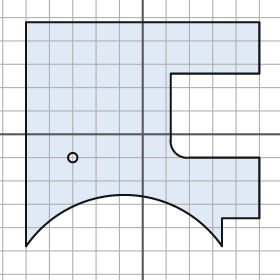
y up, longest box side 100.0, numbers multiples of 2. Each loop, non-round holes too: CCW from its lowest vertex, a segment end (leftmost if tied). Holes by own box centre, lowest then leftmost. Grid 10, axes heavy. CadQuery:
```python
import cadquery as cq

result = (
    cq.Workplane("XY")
    .moveTo(-50.0, -48.0)
    .threePointArc((-8.0, -26.0), (34.0, -48.0))
    .lineTo(34.0, -36.0)
    .lineTo(50.0, -36.0)
    .lineTo(50.0, -10.0)
    .lineTo(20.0, -10.0)
    .threePointArc((14.0, -8.0), (12.0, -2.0))
    .lineTo(12.0, 26.0)
    .lineTo(50.0, 26.0)
    .lineTo(50.0, 48.0)
    .lineTo(-50.0, 48.0)
    .close()
    .moveTo(-30.0, -10.0)
    .circle(2.0)
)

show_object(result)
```